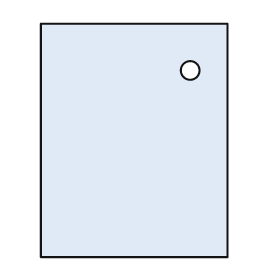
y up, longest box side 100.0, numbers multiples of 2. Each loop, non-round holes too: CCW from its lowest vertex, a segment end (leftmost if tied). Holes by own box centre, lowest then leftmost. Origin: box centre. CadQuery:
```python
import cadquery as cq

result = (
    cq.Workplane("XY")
    .moveTo(-40.0, -50.0)
    .lineTo(40.0, -50.0)
    .lineTo(40.0, 50.0)
    .lineTo(-40.0, 50.0)
    .close()
    .moveTo(24.0, 30.0)
    .circle(4.0)
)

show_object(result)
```